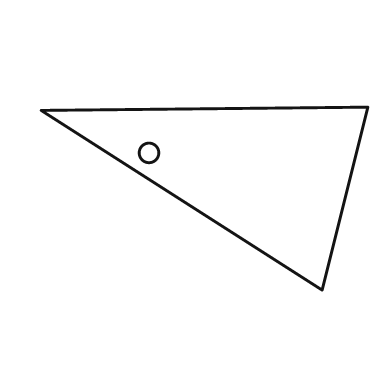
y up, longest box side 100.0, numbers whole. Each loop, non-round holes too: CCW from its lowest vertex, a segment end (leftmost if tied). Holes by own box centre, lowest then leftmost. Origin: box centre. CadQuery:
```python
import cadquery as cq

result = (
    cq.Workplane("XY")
    .moveTo(36.0, -28.0)
    .lineTo(50.0, 28.0)
    .lineTo(-50.0, 27.0)
    .close()
    .moveTo(-17.0, 14.0)
    .circle(3.0)
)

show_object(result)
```